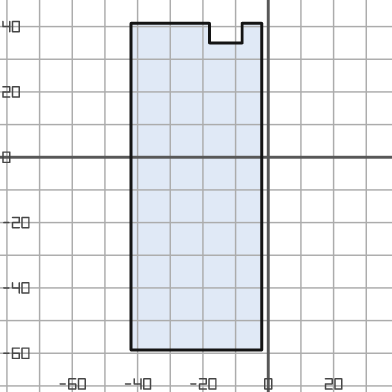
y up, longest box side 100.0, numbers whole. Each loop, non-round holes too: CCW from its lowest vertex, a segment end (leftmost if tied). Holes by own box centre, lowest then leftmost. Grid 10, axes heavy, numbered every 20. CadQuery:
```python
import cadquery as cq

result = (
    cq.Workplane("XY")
    .moveTo(-42.0, -59.0)
    .lineTo(-2.0, -59.0)
    .lineTo(-2.0, 41.0)
    .lineTo(-8.0, 41.0)
    .lineTo(-8.0, 35.0)
    .lineTo(-18.0, 35.0)
    .lineTo(-18.0, 41.0)
    .lineTo(-42.0, 41.0)
    .close()
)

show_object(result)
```